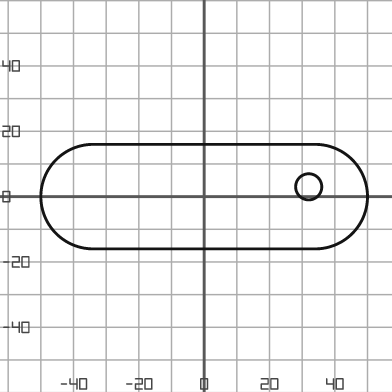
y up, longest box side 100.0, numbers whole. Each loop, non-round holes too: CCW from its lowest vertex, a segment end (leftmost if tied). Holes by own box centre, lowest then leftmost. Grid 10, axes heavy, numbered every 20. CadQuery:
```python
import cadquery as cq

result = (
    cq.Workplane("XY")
    .moveTo(-34.0, -16.0)
    .lineTo(34.0, -16.0)
    .threePointArc((50.0, 0.0), (34.0, 16.0))
    .lineTo(-34.0, 16.0)
    .threePointArc((-50.0, 0.0), (-34.0, -16.0))
    .close()
    .moveTo(32.0, 3.0)
    .circle(4.0)
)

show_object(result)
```